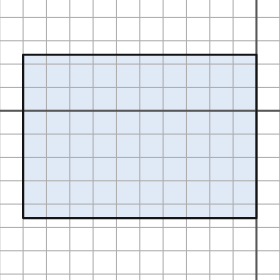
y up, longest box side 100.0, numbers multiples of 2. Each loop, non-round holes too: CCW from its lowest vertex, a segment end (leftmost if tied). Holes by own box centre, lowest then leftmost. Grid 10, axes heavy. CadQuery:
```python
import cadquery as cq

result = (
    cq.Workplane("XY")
    .moveTo(-100.0, -46.0)
    .lineTo(0.0, -46.0)
    .lineTo(0.0, 24.0)
    .lineTo(-100.0, 24.0)
    .close()
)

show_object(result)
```